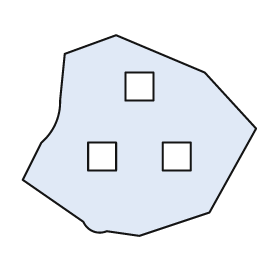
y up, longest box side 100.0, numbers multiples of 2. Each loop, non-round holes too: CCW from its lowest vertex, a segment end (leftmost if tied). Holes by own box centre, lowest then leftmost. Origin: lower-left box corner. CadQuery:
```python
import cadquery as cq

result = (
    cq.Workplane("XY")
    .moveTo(50.0, 0.0)
    .lineTo(80.0, 10.0)
    .lineTo(100.0, 46.0)
    .lineTo(78.0, 70.0)
    .lineTo(40.0, 86.0)
    .lineTo(18.0, 78.0)
    .lineTo(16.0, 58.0)
    .threePointArc((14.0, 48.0), (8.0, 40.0))
    .lineTo(0.0, 24.0)
    .lineTo(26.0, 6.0)
    .threePointArc((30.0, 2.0), (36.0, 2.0))
    .close()
    .moveTo(28.0, 28.0)
    .lineTo(40.0, 28.0)
    .lineTo(40.0, 40.0)
    .lineTo(28.0, 40.0)
    .close()
    .moveTo(60.0, 28.0)
    .lineTo(72.0, 28.0)
    .lineTo(72.0, 40.0)
    .lineTo(60.0, 40.0)
    .close()
    .moveTo(44.0, 58.0)
    .lineTo(56.0, 58.0)
    .lineTo(56.0, 70.0)
    .lineTo(44.0, 70.0)
    .close()
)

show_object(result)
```